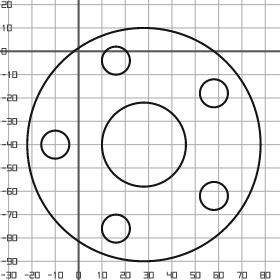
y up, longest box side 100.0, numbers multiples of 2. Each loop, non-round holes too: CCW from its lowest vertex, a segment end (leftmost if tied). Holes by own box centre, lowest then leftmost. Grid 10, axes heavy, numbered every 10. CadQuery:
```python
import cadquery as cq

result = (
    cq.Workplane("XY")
    .moveTo(28.0, -40.0)
    .circle(50.0)
    .moveTo(16.0, -76.0)
    .circle(6.0)
    .moveTo(58.0, -62.0)
    .circle(6.0)
    .moveTo(-10.0, -40.0)
    .circle(6.0)
    .moveTo(28.0, -40.0)
    .circle(18.0)
    .moveTo(58.0, -18.0)
    .circle(6.0)
    .moveTo(16.0, -4.0)
    .circle(6.0)
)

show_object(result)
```